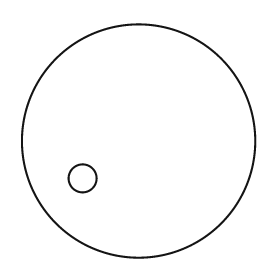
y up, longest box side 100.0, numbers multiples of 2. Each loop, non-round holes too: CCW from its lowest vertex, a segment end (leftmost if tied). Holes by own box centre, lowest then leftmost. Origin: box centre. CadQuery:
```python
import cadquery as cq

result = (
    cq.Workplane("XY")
    .moveTo(0.0, 0.0)
    .circle(50.0)
    .moveTo(-24.0, -16.0)
    .circle(6.0)
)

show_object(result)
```